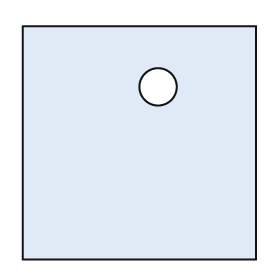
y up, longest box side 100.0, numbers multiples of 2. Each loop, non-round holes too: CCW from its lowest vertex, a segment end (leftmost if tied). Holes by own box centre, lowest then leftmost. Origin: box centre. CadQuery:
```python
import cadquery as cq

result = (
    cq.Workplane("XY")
    .moveTo(-50.0, -50.0)
    .lineTo(50.0, -50.0)
    .lineTo(50.0, 50.0)
    .lineTo(-50.0, 50.0)
    .close()
    .moveTo(8.0, 24.0)
    .circle(8.0)
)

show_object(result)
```